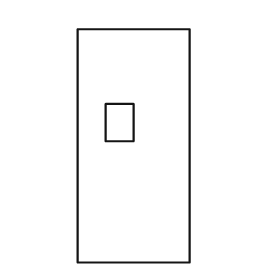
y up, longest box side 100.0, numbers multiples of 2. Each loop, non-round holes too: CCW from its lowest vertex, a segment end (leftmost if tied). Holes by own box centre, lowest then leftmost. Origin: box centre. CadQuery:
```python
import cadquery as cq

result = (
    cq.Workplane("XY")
    .moveTo(-24.0, -50.0)
    .lineTo(24.0, -50.0)
    .lineTo(24.0, 50.0)
    .lineTo(-24.0, 50.0)
    .close()
    .moveTo(-12.0, 2.0)
    .lineTo(0.0, 2.0)
    .lineTo(0.0, 18.0)
    .lineTo(-12.0, 18.0)
    .close()
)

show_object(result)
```